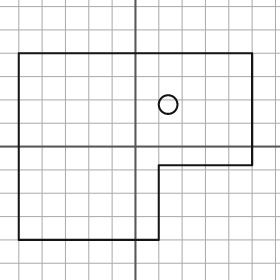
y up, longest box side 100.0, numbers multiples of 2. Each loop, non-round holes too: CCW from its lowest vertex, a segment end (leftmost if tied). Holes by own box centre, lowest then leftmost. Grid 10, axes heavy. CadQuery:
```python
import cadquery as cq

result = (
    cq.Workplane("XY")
    .moveTo(-50.0, -40.0)
    .lineTo(10.0, -40.0)
    .lineTo(10.0, -8.0)
    .lineTo(50.0, -8.0)
    .lineTo(50.0, 40.0)
    .lineTo(-50.0, 40.0)
    .close()
    .moveTo(14.0, 18.0)
    .circle(4.0)
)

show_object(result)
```